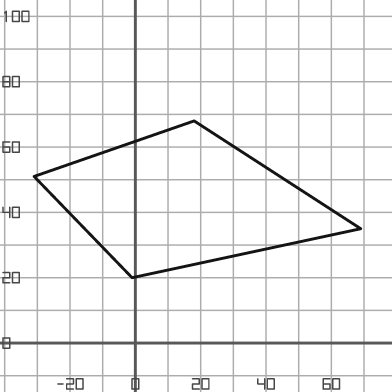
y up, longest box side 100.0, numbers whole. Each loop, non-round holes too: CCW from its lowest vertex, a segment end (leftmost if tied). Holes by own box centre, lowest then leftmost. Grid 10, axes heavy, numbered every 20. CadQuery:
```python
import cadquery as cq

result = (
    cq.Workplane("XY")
    .moveTo(-1.0, 20.0)
    .lineTo(69.0, 35.0)
    .lineTo(18.0, 68.0)
    .lineTo(-31.0, 51.0)
    .close()
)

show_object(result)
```